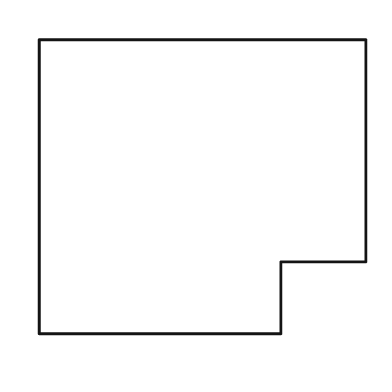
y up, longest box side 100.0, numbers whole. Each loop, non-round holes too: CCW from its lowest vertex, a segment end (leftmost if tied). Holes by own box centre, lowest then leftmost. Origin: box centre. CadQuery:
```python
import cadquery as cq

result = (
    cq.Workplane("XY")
    .moveTo(-50.0, -45.0)
    .lineTo(24.0, -45.0)
    .lineTo(24.0, -23.0)
    .lineTo(50.0, -23.0)
    .lineTo(50.0, 45.0)
    .lineTo(-50.0, 45.0)
    .close()
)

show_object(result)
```